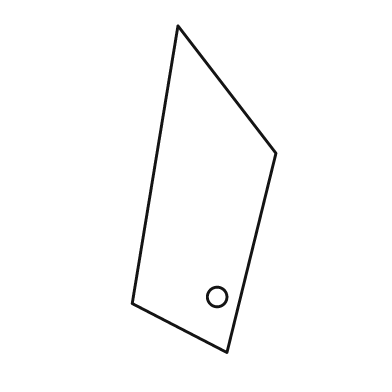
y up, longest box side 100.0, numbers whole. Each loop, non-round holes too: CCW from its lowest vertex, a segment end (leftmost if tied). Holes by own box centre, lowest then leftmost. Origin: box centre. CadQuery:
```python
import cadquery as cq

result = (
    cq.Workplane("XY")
    .moveTo(7.0, -50.0)
    .lineTo(22.0, 11.0)
    .lineTo(-8.0, 50.0)
    .lineTo(-22.0, -35.0)
    .close()
    .moveTo(4.0, -33.0)
    .circle(3.0)
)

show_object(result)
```